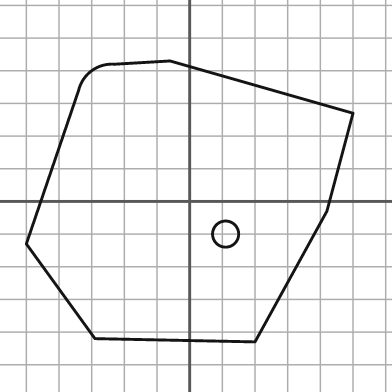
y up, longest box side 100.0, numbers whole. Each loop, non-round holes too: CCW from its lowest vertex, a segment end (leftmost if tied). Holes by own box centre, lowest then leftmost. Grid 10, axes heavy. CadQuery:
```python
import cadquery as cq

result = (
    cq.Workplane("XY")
    .moveTo(20.0, -43.0)
    .lineTo(42.0, -3.0)
    .lineTo(50.0, 27.0)
    .lineTo(-6.0, 43.0)
    .lineTo(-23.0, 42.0)
    .threePointArc((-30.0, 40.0), (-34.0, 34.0))
    .lineTo(-50.0, -13.0)
    .lineTo(-29.0, -42.0)
    .close()
    .moveTo(11.0, -10.0)
    .circle(4.0)
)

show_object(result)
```